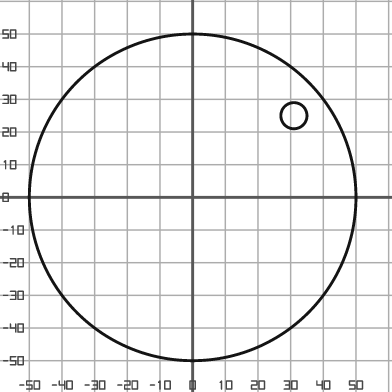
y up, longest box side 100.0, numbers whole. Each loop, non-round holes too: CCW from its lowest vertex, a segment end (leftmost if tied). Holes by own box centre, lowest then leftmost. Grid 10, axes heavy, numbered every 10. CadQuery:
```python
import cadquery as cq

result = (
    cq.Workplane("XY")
    .moveTo(0.0, 0.0)
    .circle(50.0)
    .moveTo(31.0, 25.0)
    .circle(4.0)
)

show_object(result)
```